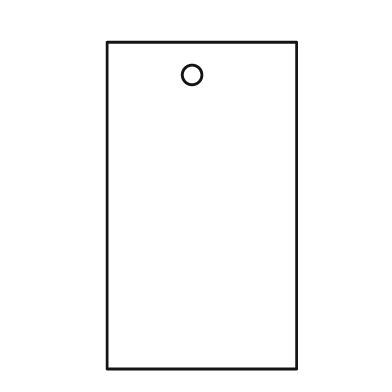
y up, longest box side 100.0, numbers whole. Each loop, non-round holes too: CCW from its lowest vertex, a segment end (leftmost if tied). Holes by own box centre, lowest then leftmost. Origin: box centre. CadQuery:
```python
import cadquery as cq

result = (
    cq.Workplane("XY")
    .moveTo(-29.0, -50.0)
    .lineTo(29.0, -50.0)
    .lineTo(29.0, 50.0)
    .lineTo(-29.0, 50.0)
    .close()
    .moveTo(-3.0, 40.0)
    .circle(3.0)
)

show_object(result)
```